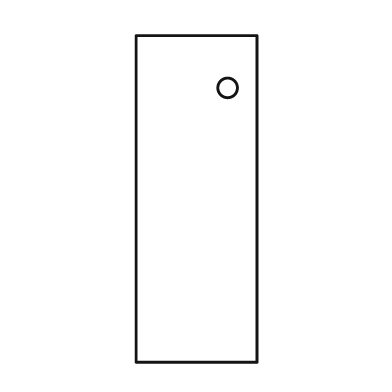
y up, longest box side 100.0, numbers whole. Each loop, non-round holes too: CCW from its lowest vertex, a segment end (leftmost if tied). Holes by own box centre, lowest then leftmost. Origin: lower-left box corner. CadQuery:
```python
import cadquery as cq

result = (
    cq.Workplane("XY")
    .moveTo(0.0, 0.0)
    .lineTo(37.0, 0.0)
    .lineTo(37.0, 100.0)
    .lineTo(0.0, 100.0)
    .close()
    .moveTo(28.0, 84.0)
    .circle(3.0)
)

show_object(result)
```